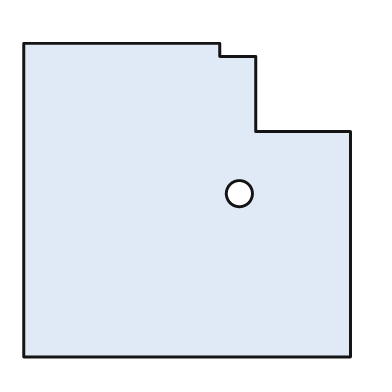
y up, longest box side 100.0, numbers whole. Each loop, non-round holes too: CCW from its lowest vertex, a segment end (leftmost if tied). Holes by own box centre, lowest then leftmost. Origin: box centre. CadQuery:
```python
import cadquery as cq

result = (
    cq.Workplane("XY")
    .moveTo(-50.0, -48.0)
    .lineTo(50.0, -48.0)
    .lineTo(50.0, 21.0)
    .lineTo(21.0, 21.0)
    .lineTo(21.0, 44.0)
    .lineTo(10.0, 44.0)
    .lineTo(10.0, 48.0)
    .lineTo(-50.0, 48.0)
    .close()
    .moveTo(16.0, 2.0)
    .circle(4.0)
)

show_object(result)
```